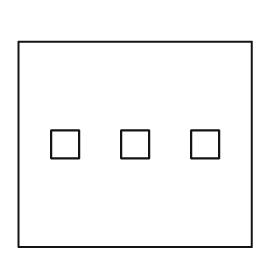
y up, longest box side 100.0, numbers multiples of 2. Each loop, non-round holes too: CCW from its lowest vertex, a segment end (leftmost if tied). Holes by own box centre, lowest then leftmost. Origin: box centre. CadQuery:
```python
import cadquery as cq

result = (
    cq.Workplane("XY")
    .moveTo(-50.0, -44.0)
    .lineTo(50.0, -44.0)
    .lineTo(50.0, 44.0)
    .lineTo(-50.0, 44.0)
    .close()
    .moveTo(-36.0, -6.0)
    .lineTo(-24.0, -6.0)
    .lineTo(-24.0, 6.0)
    .lineTo(-36.0, 6.0)
    .close()
    .moveTo(-6.0, -6.0)
    .lineTo(6.0, -6.0)
    .lineTo(6.0, 6.0)
    .lineTo(-6.0, 6.0)
    .close()
    .moveTo(24.0, -6.0)
    .lineTo(36.0, -6.0)
    .lineTo(36.0, 6.0)
    .lineTo(24.0, 6.0)
    .close()
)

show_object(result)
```